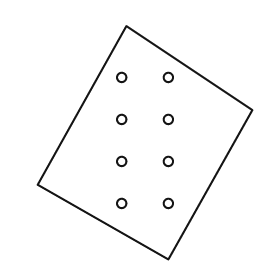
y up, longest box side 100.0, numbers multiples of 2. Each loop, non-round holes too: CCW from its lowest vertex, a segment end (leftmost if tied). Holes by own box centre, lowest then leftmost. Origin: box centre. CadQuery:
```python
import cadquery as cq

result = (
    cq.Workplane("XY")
    .moveTo(10.0, -50.0)
    .lineTo(46.0, 14.0)
    .lineTo(-8.0, 50.0)
    .lineTo(-46.0, -18.0)
    .close()
    .moveTo(-10.0, -26.0)
    .circle(2.0)
    .moveTo(10.0, -26.0)
    .circle(2.0)
    .moveTo(-10.0, -8.0)
    .circle(2.0)
    .moveTo(10.0, -8.0)
    .circle(2.0)
    .moveTo(-10.0, 10.0)
    .circle(2.0)
    .moveTo(10.0, 10.0)
    .circle(2.0)
    .moveTo(-10.0, 28.0)
    .circle(2.0)
    .moveTo(10.0, 28.0)
    .circle(2.0)
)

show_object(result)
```